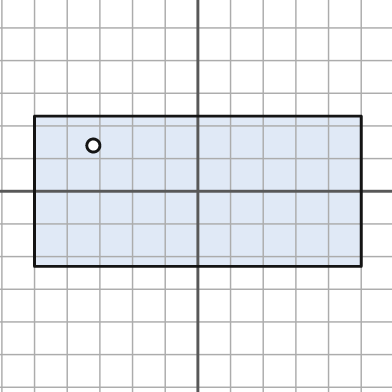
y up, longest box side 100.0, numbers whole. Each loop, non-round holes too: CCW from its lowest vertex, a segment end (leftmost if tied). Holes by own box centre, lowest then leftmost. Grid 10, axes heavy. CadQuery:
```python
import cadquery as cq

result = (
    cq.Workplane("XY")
    .moveTo(-50.0, -23.0)
    .lineTo(50.0, -23.0)
    .lineTo(50.0, 23.0)
    .lineTo(-50.0, 23.0)
    .close()
    .moveTo(-32.0, 14.0)
    .circle(2.0)
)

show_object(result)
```